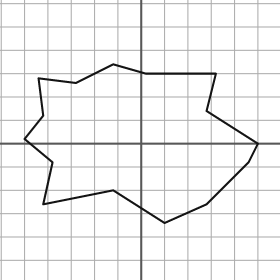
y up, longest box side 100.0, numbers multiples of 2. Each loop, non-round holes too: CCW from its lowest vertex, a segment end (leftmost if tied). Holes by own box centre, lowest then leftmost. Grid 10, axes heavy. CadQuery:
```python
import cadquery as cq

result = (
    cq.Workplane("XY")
    .moveTo(10.0, -34.0)
    .lineTo(28.0, -26.0)
    .lineTo(46.0, -8.0)
    .lineTo(50.0, 0.0)
    .lineTo(28.0, 14.0)
    .lineTo(32.0, 30.0)
    .lineTo(2.0, 30.0)
    .lineTo(-12.0, 34.0)
    .lineTo(-28.0, 26.0)
    .lineTo(-44.0, 28.0)
    .lineTo(-42.0, 12.0)
    .lineTo(-50.0, 2.0)
    .lineTo(-38.0, -8.0)
    .lineTo(-42.0, -26.0)
    .lineTo(-12.0, -20.0)
    .close()
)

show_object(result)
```